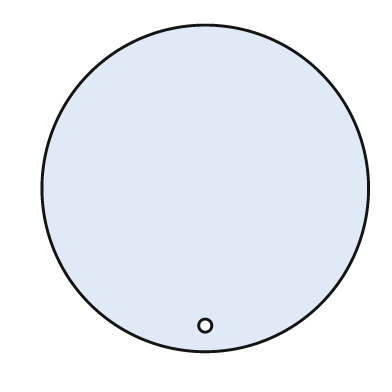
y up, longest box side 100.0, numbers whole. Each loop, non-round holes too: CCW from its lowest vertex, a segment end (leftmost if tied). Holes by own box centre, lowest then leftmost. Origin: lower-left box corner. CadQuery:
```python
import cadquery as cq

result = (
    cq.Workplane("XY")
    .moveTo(50.0, 50.0)
    .circle(50.0)
    .moveTo(50.0, 8.0)
    .circle(2.0)
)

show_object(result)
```